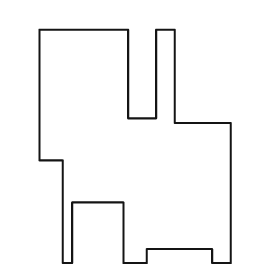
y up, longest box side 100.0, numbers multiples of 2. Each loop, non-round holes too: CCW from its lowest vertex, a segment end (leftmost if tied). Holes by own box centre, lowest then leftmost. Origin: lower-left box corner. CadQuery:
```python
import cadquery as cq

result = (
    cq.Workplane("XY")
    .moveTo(10.0, 0.0)
    .lineTo(14.0, 0.0)
    .lineTo(14.0, 26.0)
    .lineTo(36.0, 26.0)
    .lineTo(36.0, 0.0)
    .lineTo(46.0, 0.0)
    .lineTo(46.0, 6.0)
    .lineTo(74.0, 6.0)
    .lineTo(74.0, 0.0)
    .lineTo(82.0, 0.0)
    .lineTo(82.0, 60.0)
    .lineTo(58.0, 60.0)
    .lineTo(58.0, 100.0)
    .lineTo(50.0, 100.0)
    .lineTo(50.0, 62.0)
    .lineTo(38.0, 62.0)
    .lineTo(38.0, 100.0)
    .lineTo(0.0, 100.0)
    .lineTo(0.0, 44.0)
    .lineTo(10.0, 44.0)
    .close()
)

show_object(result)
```